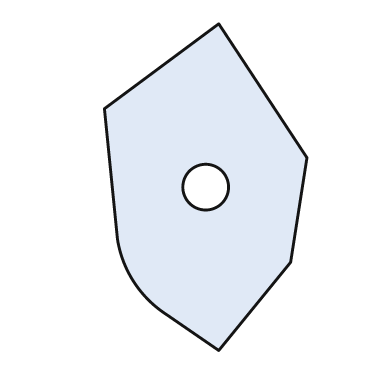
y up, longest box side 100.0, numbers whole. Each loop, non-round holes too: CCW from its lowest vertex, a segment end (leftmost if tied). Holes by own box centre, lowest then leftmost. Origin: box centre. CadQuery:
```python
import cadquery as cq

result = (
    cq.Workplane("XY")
    .moveTo(4.0, -50.0)
    .lineTo(26.0, -23.0)
    .lineTo(31.0, 9.0)
    .lineTo(4.0, 50.0)
    .lineTo(-31.0, 24.0)
    .lineTo(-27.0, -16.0)
    .threePointArc((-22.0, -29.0), (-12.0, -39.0))
    .close()
    .moveTo(0.0, 0.0)
    .circle(7.0)
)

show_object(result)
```